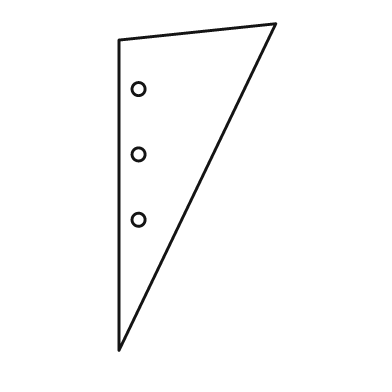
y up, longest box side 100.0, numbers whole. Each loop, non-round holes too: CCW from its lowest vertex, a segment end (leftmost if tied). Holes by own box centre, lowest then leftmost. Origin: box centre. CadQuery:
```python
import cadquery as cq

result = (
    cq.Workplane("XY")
    .moveTo(-24.0, -50.0)
    .lineTo(24.0, 50.0)
    .lineTo(-24.0, 45.0)
    .close()
    .moveTo(-18.0, -10.0)
    .circle(2.0)
    .moveTo(-18.0, 10.0)
    .circle(2.0)
    .moveTo(-18.0, 30.0)
    .circle(2.0)
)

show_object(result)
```